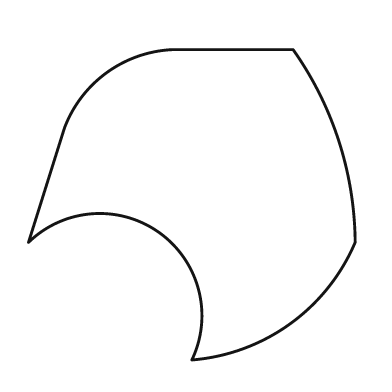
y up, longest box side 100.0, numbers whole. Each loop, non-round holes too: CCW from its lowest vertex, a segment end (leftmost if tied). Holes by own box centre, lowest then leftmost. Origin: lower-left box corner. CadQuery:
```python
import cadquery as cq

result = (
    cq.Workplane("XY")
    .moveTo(50.0, 0.0)
    .threePointArc((80.0, 11.0), (100.0, 36.0))
    .threePointArc((95.0, 67.0), (81.0, 95.0))
    .lineTo(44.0, 95.0)
    .threePointArc((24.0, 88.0), (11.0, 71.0))
    .lineTo(0.0, 36.0)
    .threePointArc((40.0, 39.0), (50.0, 0.0))
    .close()
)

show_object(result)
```